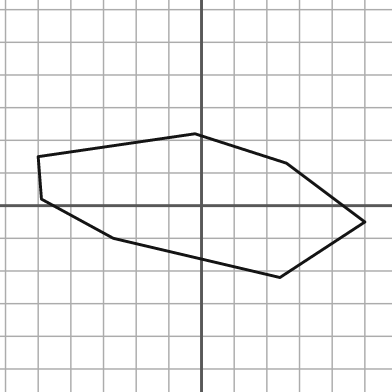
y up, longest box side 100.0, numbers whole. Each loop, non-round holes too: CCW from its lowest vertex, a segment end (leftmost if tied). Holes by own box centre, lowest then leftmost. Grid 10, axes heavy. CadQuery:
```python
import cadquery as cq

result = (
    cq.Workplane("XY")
    .moveTo(24.0, -22.0)
    .lineTo(50.0, -5.0)
    .lineTo(26.0, 13.0)
    .lineTo(-2.0, 22.0)
    .lineTo(-50.0, 15.0)
    .lineTo(-49.0, 2.0)
    .lineTo(-27.0, -10.0)
    .close()
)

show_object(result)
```